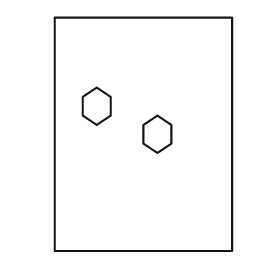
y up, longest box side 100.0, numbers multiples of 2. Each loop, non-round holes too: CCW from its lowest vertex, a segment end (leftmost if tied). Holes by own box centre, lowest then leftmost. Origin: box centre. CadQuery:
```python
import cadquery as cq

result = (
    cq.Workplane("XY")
    .moveTo(-38.0, -50.0)
    .lineTo(38.0, -50.0)
    .lineTo(38.0, 50.0)
    .lineTo(-38.0, 50.0)
    .close()
    .moveTo(6.0, -8.0)
    .lineTo(12.0, -4.0)
    .lineTo(12.0, 4.0)
    .lineTo(6.0, 8.0)
    .lineTo(0.0, 4.0)
    .lineTo(0.0, -4.0)
    .close()
    .moveTo(-20.0, 4.0)
    .lineTo(-14.0, 8.0)
    .lineTo(-14.0, 16.0)
    .lineTo(-20.0, 20.0)
    .lineTo(-26.0, 16.0)
    .lineTo(-26.0, 8.0)
    .close()
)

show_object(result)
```